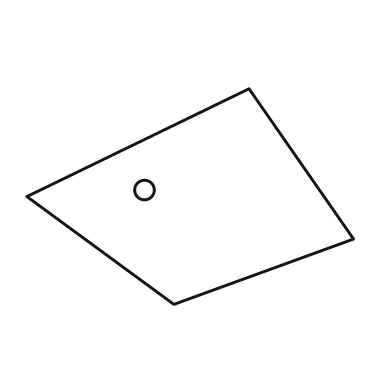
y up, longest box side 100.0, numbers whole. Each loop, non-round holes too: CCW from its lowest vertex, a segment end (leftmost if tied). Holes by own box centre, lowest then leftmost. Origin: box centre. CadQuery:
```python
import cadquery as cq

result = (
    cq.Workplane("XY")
    .moveTo(-5.0, -33.0)
    .lineTo(50.0, -13.0)
    .lineTo(18.0, 33.0)
    .lineTo(-50.0, 0.0)
    .close()
    .moveTo(-14.0, 2.0)
    .circle(3.0)
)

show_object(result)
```